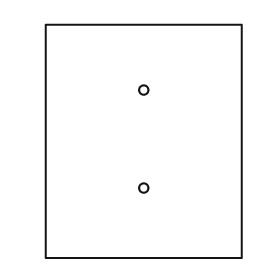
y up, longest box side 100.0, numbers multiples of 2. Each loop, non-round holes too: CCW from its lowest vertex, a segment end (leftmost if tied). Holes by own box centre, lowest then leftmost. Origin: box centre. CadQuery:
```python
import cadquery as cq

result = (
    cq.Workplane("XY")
    .moveTo(-42.0, -50.0)
    .lineTo(42.0, -50.0)
    .lineTo(42.0, 50.0)
    .lineTo(-42.0, 50.0)
    .close()
    .moveTo(0.0, -20.0)
    .circle(2.0)
    .moveTo(0.0, 22.0)
    .circle(2.0)
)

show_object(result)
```